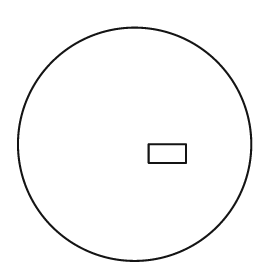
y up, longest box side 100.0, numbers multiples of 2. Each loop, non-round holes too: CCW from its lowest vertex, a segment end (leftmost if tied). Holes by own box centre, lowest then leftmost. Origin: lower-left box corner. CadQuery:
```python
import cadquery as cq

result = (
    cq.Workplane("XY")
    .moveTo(50.0, 50.0)
    .circle(50.0)
    .moveTo(56.0, 42.0)
    .lineTo(72.0, 42.0)
    .lineTo(72.0, 50.0)
    .lineTo(56.0, 50.0)
    .close()
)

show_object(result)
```